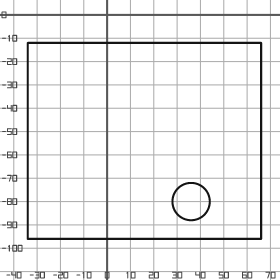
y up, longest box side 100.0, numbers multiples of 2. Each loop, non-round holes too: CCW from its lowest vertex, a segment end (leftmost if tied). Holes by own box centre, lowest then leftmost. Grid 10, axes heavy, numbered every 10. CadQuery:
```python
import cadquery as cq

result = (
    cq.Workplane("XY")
    .moveTo(-34.0, -96.0)
    .lineTo(66.0, -96.0)
    .lineTo(66.0, -12.0)
    .lineTo(-34.0, -12.0)
    .close()
    .moveTo(36.0, -80.0)
    .circle(8.0)
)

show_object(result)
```